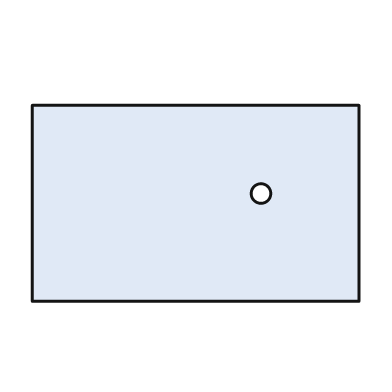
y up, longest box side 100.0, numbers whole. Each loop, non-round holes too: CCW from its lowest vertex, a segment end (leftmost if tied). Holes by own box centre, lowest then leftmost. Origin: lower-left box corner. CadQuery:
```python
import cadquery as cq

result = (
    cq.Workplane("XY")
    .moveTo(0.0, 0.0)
    .lineTo(100.0, 0.0)
    .lineTo(100.0, 60.0)
    .lineTo(0.0, 60.0)
    .close()
    .moveTo(70.0, 33.0)
    .circle(3.0)
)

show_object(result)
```